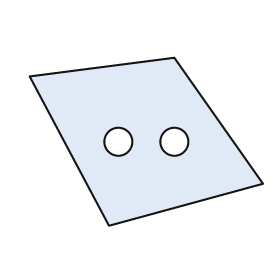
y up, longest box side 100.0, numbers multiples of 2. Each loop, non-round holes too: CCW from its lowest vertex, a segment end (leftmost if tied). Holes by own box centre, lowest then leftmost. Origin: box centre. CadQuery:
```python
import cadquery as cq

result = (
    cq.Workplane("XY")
    .moveTo(-16.0, -36.0)
    .lineTo(50.0, -18.0)
    .lineTo(12.0, 36.0)
    .lineTo(-50.0, 28.0)
    .close()
    .moveTo(-12.0, 0.0)
    .circle(6.0)
    .moveTo(12.0, 0.0)
    .circle(6.0)
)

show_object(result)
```